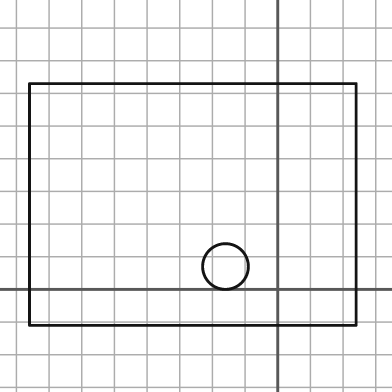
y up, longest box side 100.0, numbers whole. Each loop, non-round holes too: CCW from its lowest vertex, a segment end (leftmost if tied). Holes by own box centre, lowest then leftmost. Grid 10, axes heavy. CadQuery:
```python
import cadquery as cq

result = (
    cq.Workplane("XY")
    .moveTo(-76.0, -11.0)
    .lineTo(24.0, -11.0)
    .lineTo(24.0, 63.0)
    .lineTo(-76.0, 63.0)
    .close()
    .moveTo(-16.0, 7.0)
    .circle(7.0)
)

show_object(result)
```